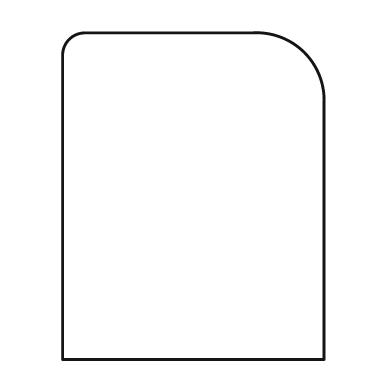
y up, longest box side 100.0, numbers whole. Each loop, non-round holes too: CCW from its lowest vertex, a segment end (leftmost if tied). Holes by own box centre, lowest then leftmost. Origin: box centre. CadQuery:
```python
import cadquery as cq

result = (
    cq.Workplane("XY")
    .moveTo(-40.0, -50.0)
    .lineTo(40.0, -50.0)
    .lineTo(40.0, 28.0)
    .threePointArc((34.0, 44.0), (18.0, 50.0))
    .lineTo(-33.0, 50.0)
    .threePointArc((-38.0, 48.0), (-40.0, 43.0))
    .close()
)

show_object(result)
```